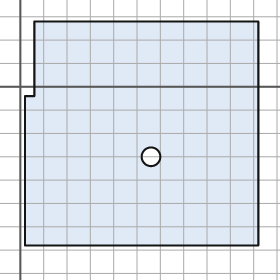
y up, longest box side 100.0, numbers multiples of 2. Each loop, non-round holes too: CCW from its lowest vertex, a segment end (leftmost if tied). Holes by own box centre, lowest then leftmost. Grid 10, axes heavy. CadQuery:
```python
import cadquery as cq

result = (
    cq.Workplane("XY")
    .moveTo(2.0, -68.0)
    .lineTo(102.0, -68.0)
    .lineTo(102.0, 28.0)
    .lineTo(6.0, 28.0)
    .lineTo(6.0, -4.0)
    .lineTo(2.0, -4.0)
    .close()
    .moveTo(56.0, -30.0)
    .circle(4.0)
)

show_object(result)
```